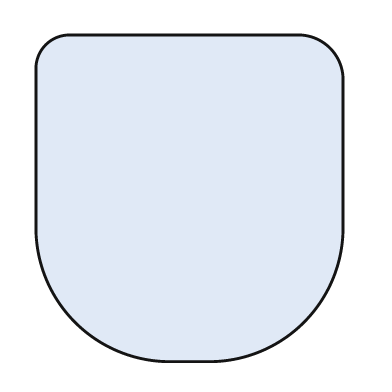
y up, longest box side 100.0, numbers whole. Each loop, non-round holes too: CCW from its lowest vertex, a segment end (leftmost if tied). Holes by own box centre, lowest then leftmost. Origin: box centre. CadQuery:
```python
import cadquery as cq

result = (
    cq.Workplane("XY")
    .moveTo(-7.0, -50.0)
    .lineTo(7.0, -50.0)
    .threePointArc((35.0, -38.0), (47.0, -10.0))
    .lineTo(47.0, 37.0)
    .threePointArc((43.0, 46.0), (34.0, 50.0))
    .lineTo(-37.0, 50.0)
    .threePointArc((-44.0, 47.0), (-47.0, 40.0))
    .lineTo(-47.0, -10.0)
    .threePointArc((-35.0, -38.0), (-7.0, -50.0))
    .close()
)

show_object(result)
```